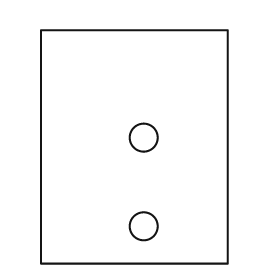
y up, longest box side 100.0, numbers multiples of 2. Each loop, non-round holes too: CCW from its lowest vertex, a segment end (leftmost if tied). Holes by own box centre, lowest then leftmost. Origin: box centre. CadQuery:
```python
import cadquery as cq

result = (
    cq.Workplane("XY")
    .moveTo(-40.0, -50.0)
    .lineTo(40.0, -50.0)
    .lineTo(40.0, 50.0)
    .lineTo(-40.0, 50.0)
    .close()
    .moveTo(4.0, -34.0)
    .circle(6.0)
    .moveTo(4.0, 4.0)
    .circle(6.0)
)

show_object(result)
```